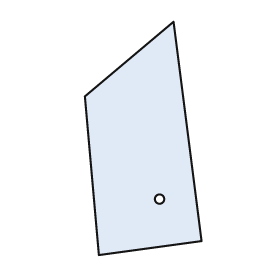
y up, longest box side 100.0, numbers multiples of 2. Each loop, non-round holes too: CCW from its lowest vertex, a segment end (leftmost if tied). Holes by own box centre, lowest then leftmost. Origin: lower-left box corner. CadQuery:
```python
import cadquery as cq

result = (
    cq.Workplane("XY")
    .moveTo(6.0, 0.0)
    .lineTo(50.0, 6.0)
    .lineTo(38.0, 100.0)
    .lineTo(0.0, 68.0)
    .close()
    .moveTo(32.0, 24.0)
    .circle(2.0)
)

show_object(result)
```